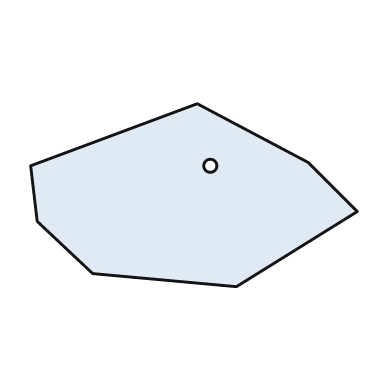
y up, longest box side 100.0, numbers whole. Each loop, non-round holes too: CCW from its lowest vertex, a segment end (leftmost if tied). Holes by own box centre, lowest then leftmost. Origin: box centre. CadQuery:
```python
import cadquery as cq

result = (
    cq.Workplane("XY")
    .moveTo(13.0, -28.0)
    .lineTo(50.0, -5.0)
    .lineTo(35.0, 10.0)
    .lineTo(1.0, 28.0)
    .lineTo(-50.0, 9.0)
    .lineTo(-48.0, -8.0)
    .lineTo(-31.0, -24.0)
    .close()
    .moveTo(5.0, 9.0)
    .circle(2.0)
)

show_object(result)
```